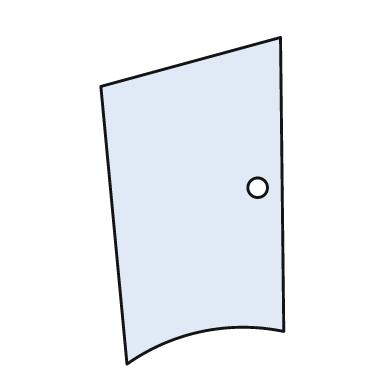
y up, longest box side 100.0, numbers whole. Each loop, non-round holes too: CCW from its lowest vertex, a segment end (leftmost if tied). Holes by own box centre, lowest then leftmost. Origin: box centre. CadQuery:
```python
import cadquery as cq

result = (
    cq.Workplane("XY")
    .moveTo(-20.0, -50.0)
    .threePointArc((3.0, -40.0), (28.0, -40.0))
    .lineTo(27.0, 50.0)
    .lineTo(-28.0, 35.0)
    .close()
    .moveTo(20.0, 4.0)
    .circle(3.0)
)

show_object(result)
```